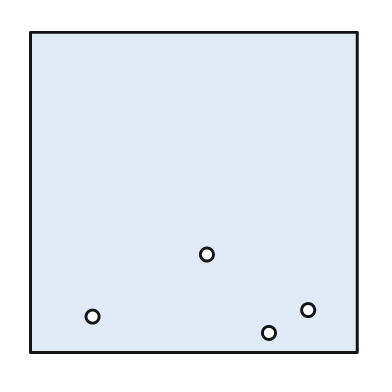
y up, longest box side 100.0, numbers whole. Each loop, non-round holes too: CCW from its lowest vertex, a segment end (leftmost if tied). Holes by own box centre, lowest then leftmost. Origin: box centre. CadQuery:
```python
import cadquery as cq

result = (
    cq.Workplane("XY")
    .moveTo(-50.0, -49.0)
    .lineTo(50.0, -49.0)
    .lineTo(50.0, 49.0)
    .lineTo(-50.0, 49.0)
    .close()
    .moveTo(23.0, -43.0)
    .circle(2.0)
    .moveTo(-31.0, -38.0)
    .circle(2.0)
    .moveTo(35.0, -36.0)
    .circle(2.0)
    .moveTo(4.0, -19.0)
    .circle(2.0)
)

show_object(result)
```